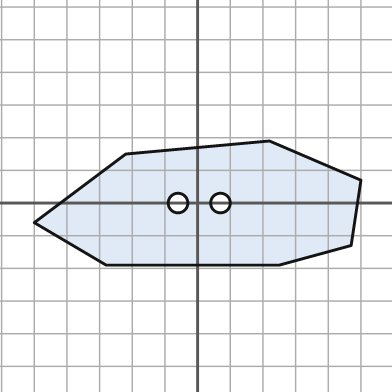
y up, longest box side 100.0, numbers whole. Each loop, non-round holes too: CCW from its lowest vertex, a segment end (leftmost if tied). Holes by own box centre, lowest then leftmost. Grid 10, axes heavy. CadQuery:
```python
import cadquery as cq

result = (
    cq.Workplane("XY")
    .moveTo(-28.0, -19.0)
    .lineTo(25.0, -19.0)
    .lineTo(47.0, -13.0)
    .lineTo(50.0, 7.0)
    .lineTo(22.0, 19.0)
    .lineTo(-22.0, 15.0)
    .lineTo(-50.0, -6.0)
    .close()
    .moveTo(-6.0, 0.0)
    .circle(3.0)
    .moveTo(7.0, 0.0)
    .circle(3.0)
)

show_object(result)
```